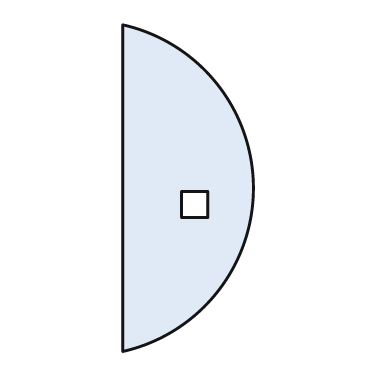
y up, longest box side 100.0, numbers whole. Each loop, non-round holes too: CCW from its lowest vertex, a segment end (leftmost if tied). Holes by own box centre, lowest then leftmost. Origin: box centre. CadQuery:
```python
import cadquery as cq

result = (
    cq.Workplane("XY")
    .moveTo(-20.0, -50.0)
    .threePointArc((20.0, 0.0), (-20.0, 50.0))
    .close()
    .moveTo(-2.0, -9.0)
    .lineTo(6.0, -9.0)
    .lineTo(6.0, -1.0)
    .lineTo(-2.0, -1.0)
    .close()
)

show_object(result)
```